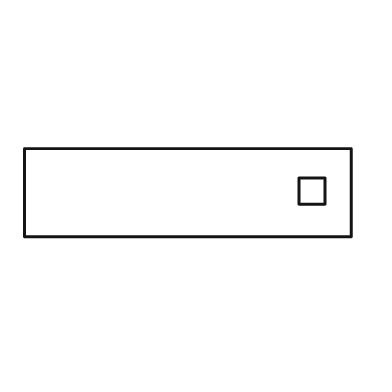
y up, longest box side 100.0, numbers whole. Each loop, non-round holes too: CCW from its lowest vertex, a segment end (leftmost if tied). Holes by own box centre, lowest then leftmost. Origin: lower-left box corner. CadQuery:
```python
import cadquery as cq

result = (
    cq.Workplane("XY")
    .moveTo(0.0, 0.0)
    .lineTo(100.0, 0.0)
    .lineTo(100.0, 27.0)
    .lineTo(0.0, 27.0)
    .close()
    .moveTo(84.0, 10.0)
    .lineTo(92.0, 10.0)
    .lineTo(92.0, 18.0)
    .lineTo(84.0, 18.0)
    .close()
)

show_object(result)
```